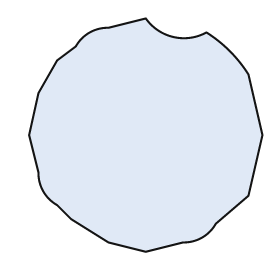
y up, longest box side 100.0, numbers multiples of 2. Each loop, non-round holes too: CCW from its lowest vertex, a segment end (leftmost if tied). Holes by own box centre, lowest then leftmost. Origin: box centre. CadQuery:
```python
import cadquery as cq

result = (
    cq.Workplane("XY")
    .moveTo(0.0, -50.0)
    .lineTo(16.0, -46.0)
    .threePointArc((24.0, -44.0), (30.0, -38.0))
    .lineTo(44.0, -26.0)
    .lineTo(50.0, 0.0)
    .lineTo(44.0, 26.0)
    .threePointArc((36.0, 36.0), (26.0, 44.0))
    .threePointArc((12.0, 42.0), (0.0, 50.0))
    .lineTo(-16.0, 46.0)
    .threePointArc((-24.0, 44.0), (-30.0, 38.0))
    .lineTo(-38.0, 32.0)
    .lineTo(-46.0, 18.0)
    .lineTo(-50.0, 0.0)
    .lineTo(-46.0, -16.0)
    .threePointArc((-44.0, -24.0), (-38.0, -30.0))
    .lineTo(-32.0, -36.0)
    .lineTo(-16.0, -46.0)
    .close()
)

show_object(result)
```